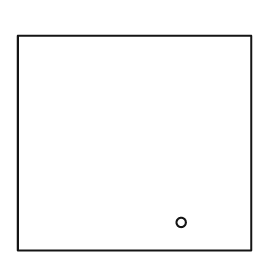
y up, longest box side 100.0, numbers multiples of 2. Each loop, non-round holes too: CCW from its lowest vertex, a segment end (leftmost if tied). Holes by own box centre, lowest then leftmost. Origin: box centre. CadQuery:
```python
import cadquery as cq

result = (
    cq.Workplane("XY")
    .moveTo(-50.0, -46.0)
    .lineTo(50.0, -46.0)
    .lineTo(50.0, 46.0)
    .lineTo(-50.0, 46.0)
    .close()
    .moveTo(20.0, -34.0)
    .circle(2.0)
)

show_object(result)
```